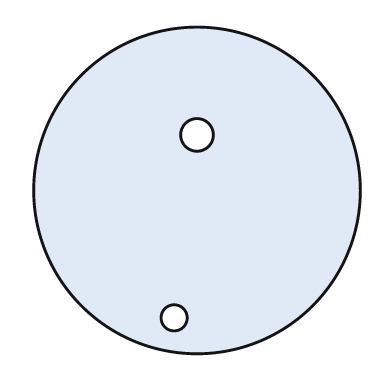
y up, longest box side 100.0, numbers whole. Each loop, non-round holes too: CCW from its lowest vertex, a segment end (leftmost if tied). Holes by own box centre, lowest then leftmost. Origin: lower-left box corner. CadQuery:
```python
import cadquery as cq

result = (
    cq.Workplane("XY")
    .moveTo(50.0, 50.0)
    .circle(50.0)
    .moveTo(43.0, 11.0)
    .circle(4.0)
    .moveTo(50.0, 67.0)
    .circle(5.0)
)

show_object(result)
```